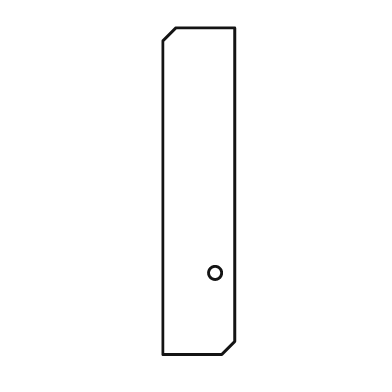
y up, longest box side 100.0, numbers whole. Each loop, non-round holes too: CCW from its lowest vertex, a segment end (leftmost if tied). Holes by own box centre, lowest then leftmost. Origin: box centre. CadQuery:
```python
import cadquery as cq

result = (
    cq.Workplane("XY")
    .moveTo(-11.0, -50.0)
    .lineTo(7.0, -50.0)
    .lineTo(11.0, -46.0)
    .lineTo(11.0, 50.0)
    .lineTo(-7.0, 50.0)
    .lineTo(-11.0, 46.0)
    .close()
    .moveTo(5.0, -25.0)
    .circle(2.0)
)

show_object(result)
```